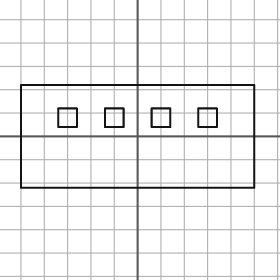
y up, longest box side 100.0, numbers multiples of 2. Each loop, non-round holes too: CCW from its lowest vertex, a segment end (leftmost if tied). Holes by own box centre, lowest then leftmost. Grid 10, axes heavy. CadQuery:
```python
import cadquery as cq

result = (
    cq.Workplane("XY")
    .moveTo(-50.0, -22.0)
    .lineTo(50.0, -22.0)
    .lineTo(50.0, 22.0)
    .lineTo(-50.0, 22.0)
    .close()
    .moveTo(-34.0, 4.0)
    .lineTo(-26.0, 4.0)
    .lineTo(-26.0, 12.0)
    .lineTo(-34.0, 12.0)
    .close()
    .moveTo(-14.0, 4.0)
    .lineTo(-6.0, 4.0)
    .lineTo(-6.0, 12.0)
    .lineTo(-14.0, 12.0)
    .close()
    .moveTo(6.0, 4.0)
    .lineTo(14.0, 4.0)
    .lineTo(14.0, 12.0)
    .lineTo(6.0, 12.0)
    .close()
    .moveTo(26.0, 4.0)
    .lineTo(34.0, 4.0)
    .lineTo(34.0, 12.0)
    .lineTo(26.0, 12.0)
    .close()
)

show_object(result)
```